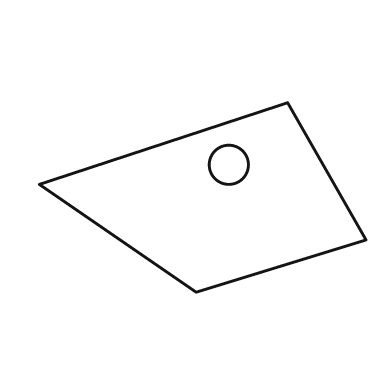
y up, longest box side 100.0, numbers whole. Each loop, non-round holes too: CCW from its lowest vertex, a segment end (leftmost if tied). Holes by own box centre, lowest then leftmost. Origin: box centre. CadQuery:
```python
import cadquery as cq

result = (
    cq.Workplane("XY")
    .moveTo(-2.0, -29.0)
    .lineTo(50.0, -13.0)
    .lineTo(26.0, 29.0)
    .lineTo(-50.0, 4.0)
    .close()
    .moveTo(8.0, 10.0)
    .circle(6.0)
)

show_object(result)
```